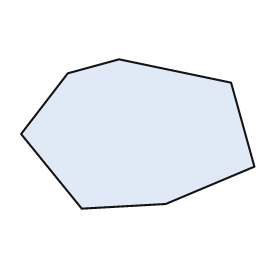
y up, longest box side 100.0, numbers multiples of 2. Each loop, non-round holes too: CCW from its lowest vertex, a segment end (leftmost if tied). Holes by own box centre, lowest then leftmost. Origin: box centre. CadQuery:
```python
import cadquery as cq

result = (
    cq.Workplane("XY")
    .moveTo(-24.0, -32.0)
    .lineTo(12.0, -30.0)
    .lineTo(50.0, -14.0)
    .lineTo(40.0, 22.0)
    .lineTo(-8.0, 32.0)
    .lineTo(-30.0, 26.0)
    .lineTo(-50.0, 0.0)
    .close()
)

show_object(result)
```